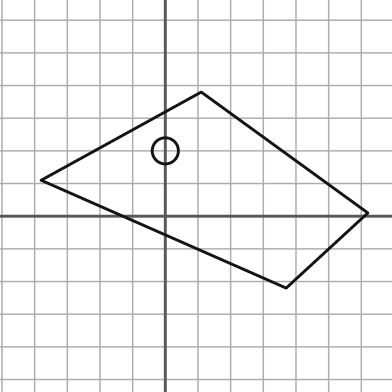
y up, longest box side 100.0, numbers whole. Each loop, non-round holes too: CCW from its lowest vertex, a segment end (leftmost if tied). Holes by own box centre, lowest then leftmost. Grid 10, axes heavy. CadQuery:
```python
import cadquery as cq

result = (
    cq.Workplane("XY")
    .moveTo(37.0, -22.0)
    .lineTo(62.0, 1.0)
    .lineTo(11.0, 38.0)
    .lineTo(-38.0, 11.0)
    .close()
    .moveTo(0.0, 20.0)
    .circle(4.0)
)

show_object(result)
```